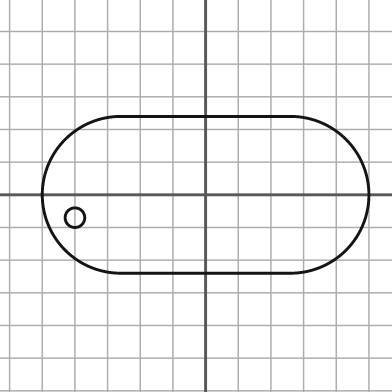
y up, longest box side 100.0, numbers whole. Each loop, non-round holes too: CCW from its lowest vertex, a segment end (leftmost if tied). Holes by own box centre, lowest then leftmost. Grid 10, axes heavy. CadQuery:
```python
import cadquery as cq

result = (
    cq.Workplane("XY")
    .moveTo(-26.0, -24.0)
    .lineTo(26.0, -24.0)
    .threePointArc((50.0, 0.0), (26.0, 24.0))
    .lineTo(-26.0, 24.0)
    .threePointArc((-50.0, 0.0), (-26.0, -24.0))
    .close()
    .moveTo(-40.0, -7.0)
    .circle(3.0)
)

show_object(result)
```